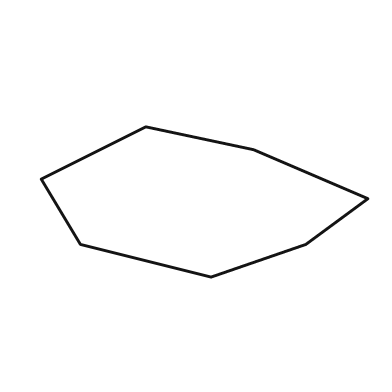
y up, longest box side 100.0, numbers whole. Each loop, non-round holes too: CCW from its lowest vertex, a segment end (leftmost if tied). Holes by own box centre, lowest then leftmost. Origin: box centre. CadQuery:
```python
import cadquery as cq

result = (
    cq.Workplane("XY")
    .moveTo(2.0, -23.0)
    .lineTo(31.0, -13.0)
    .lineTo(50.0, 1.0)
    .lineTo(15.0, 16.0)
    .lineTo(-18.0, 23.0)
    .lineTo(-50.0, 7.0)
    .lineTo(-38.0, -13.0)
    .close()
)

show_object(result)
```